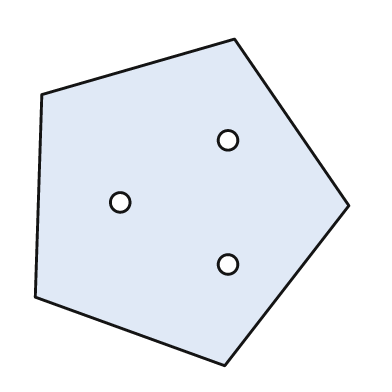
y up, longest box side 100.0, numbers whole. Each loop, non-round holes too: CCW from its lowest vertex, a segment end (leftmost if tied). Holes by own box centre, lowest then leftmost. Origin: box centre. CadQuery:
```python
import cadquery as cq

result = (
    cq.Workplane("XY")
    .moveTo(10.0, -50.0)
    .lineTo(48.0, -1.0)
    .lineTo(13.0, 50.0)
    .lineTo(-46.0, 33.0)
    .lineTo(-48.0, -29.0)
    .close()
    .moveTo(11.0, -19.0)
    .circle(3.0)
    .moveTo(-22.0, 0.0)
    .circle(3.0)
    .moveTo(11.0, 19.0)
    .circle(3.0)
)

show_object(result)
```